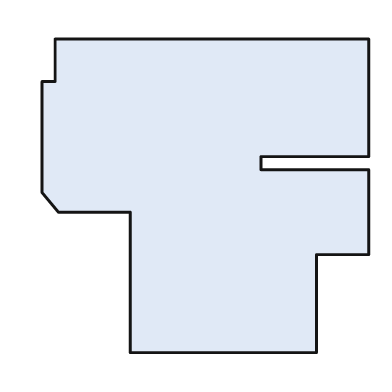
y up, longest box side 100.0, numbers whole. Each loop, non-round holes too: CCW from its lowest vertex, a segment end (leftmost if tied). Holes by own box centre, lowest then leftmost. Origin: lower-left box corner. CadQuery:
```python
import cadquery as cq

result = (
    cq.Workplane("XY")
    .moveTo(27.0, 0.0)
    .lineTo(84.0, 0.0)
    .lineTo(84.0, 30.0)
    .lineTo(100.0, 30.0)
    .lineTo(100.0, 56.0)
    .lineTo(67.0, 56.0)
    .lineTo(67.0, 60.0)
    .lineTo(100.0, 60.0)
    .lineTo(100.0, 96.0)
    .lineTo(4.0, 96.0)
    .lineTo(4.0, 83.0)
    .lineTo(0.0, 83.0)
    .lineTo(0.0, 49.0)
    .lineTo(5.0, 43.0)
    .lineTo(27.0, 43.0)
    .close()
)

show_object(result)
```